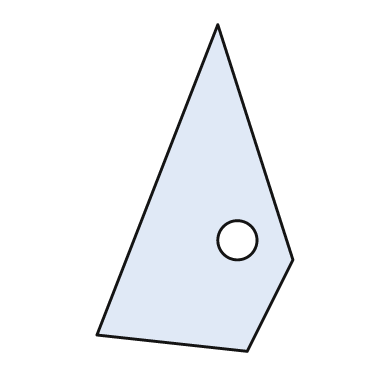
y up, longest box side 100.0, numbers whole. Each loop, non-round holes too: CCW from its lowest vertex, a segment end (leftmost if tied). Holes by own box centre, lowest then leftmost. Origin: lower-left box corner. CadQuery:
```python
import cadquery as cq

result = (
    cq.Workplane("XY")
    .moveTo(46.0, 0.0)
    .lineTo(60.0, 28.0)
    .lineTo(37.0, 100.0)
    .lineTo(0.0, 5.0)
    .close()
    .moveTo(43.0, 34.0)
    .circle(6.0)
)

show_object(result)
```